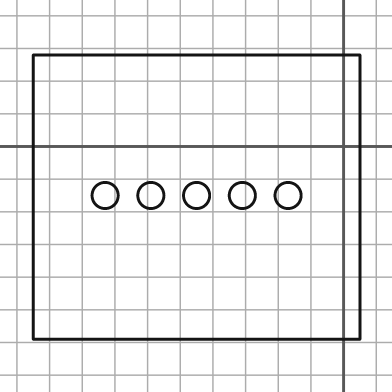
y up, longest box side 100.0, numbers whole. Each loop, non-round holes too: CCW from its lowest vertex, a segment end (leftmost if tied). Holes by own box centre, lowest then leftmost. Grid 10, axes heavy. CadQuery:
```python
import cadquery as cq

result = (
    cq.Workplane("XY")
    .moveTo(-95.0, -59.0)
    .lineTo(5.0, -59.0)
    .lineTo(5.0, 28.0)
    .lineTo(-95.0, 28.0)
    .close()
    .moveTo(-73.0, -15.0)
    .circle(4.0)
    .moveTo(-59.0, -15.0)
    .circle(4.0)
    .moveTo(-45.0, -15.0)
    .circle(4.0)
    .moveTo(-31.0, -15.0)
    .circle(4.0)
    .moveTo(-17.0, -15.0)
    .circle(4.0)
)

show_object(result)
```